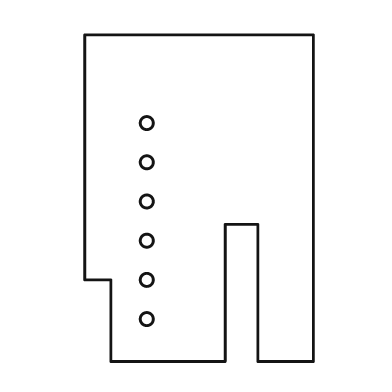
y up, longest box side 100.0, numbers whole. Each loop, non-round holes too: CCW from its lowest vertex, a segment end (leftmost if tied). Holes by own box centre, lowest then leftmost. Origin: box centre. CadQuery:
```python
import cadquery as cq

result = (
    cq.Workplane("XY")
    .moveTo(-27.0, -50.0)
    .lineTo(8.0, -50.0)
    .lineTo(8.0, -8.0)
    .lineTo(18.0, -8.0)
    .lineTo(18.0, -50.0)
    .lineTo(35.0, -50.0)
    .lineTo(35.0, 50.0)
    .lineTo(-35.0, 50.0)
    .lineTo(-35.0, -25.0)
    .lineTo(-27.0, -25.0)
    .close()
    .moveTo(-16.0, -37.0)
    .circle(2.0)
    .moveTo(-16.0, -25.0)
    .circle(2.0)
    .moveTo(-16.0, -13.0)
    .circle(2.0)
    .moveTo(-16.0, -1.0)
    .circle(2.0)
    .moveTo(-16.0, 11.0)
    .circle(2.0)
    .moveTo(-16.0, 23.0)
    .circle(2.0)
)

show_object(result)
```